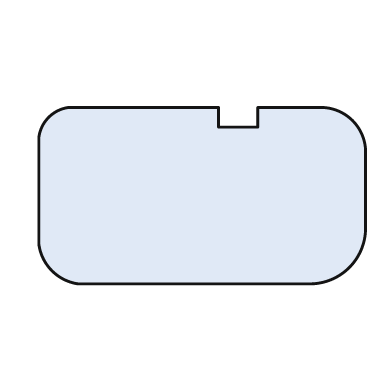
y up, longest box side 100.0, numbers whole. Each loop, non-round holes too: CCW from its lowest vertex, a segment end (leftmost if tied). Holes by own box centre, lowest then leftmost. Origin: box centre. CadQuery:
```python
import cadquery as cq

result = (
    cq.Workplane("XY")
    .moveTo(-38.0, -27.0)
    .lineTo(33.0, -27.0)
    .threePointArc((45.0, -22.0), (50.0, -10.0))
    .lineTo(50.0, 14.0)
    .threePointArc((46.0, 23.0), (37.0, 27.0))
    .lineTo(17.0, 27.0)
    .lineTo(17.0, 21.0)
    .lineTo(5.0, 21.0)
    .lineTo(5.0, 27.0)
    .lineTo(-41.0, 27.0)
    .threePointArc((-47.0, 24.0), (-50.0, 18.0))
    .lineTo(-50.0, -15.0)
    .threePointArc((-46.0, -23.0), (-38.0, -27.0))
    .close()
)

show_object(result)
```